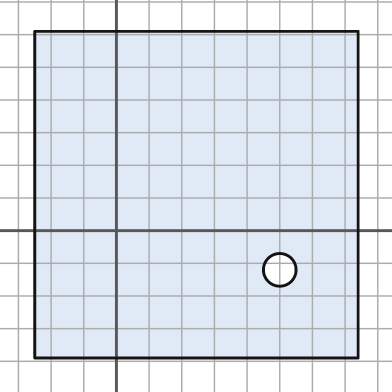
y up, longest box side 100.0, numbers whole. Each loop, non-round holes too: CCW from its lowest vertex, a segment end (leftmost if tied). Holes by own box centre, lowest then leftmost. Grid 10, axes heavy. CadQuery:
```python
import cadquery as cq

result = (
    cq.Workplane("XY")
    .moveTo(-25.0, -39.0)
    .lineTo(74.0, -39.0)
    .lineTo(74.0, 61.0)
    .lineTo(-25.0, 61.0)
    .close()
    .moveTo(50.0, -12.0)
    .circle(5.0)
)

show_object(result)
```